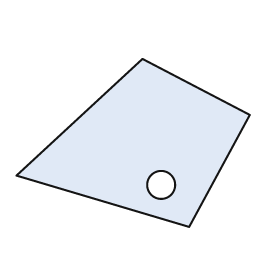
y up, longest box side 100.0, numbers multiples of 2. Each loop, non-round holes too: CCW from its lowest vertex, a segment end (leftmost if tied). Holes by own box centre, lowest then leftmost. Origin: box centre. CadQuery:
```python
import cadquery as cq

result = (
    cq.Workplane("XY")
    .moveTo(24.0, -36.0)
    .lineTo(50.0, 12.0)
    .lineTo(4.0, 36.0)
    .lineTo(-50.0, -14.0)
    .close()
    .moveTo(12.0, -18.0)
    .circle(6.0)
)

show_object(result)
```